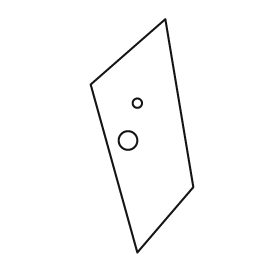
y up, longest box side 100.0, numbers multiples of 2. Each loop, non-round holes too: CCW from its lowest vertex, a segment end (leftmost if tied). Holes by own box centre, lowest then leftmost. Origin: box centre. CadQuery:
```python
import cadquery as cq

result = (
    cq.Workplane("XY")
    .moveTo(-2.0, -50.0)
    .lineTo(22.0, -22.0)
    .lineTo(10.0, 50.0)
    .lineTo(-22.0, 22.0)
    .close()
    .moveTo(-6.0, -2.0)
    .circle(4.0)
    .moveTo(-2.0, 14.0)
    .circle(2.0)
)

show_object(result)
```